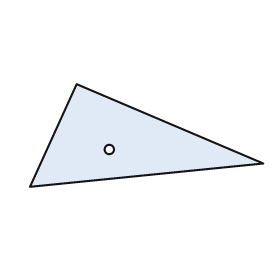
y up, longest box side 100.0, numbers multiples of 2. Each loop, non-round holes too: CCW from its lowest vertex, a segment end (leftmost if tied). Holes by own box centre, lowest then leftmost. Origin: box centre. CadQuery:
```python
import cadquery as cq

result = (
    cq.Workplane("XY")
    .moveTo(-50.0, -22.0)
    .lineTo(50.0, -12.0)
    .lineTo(-30.0, 22.0)
    .close()
    .moveTo(-16.0, -6.0)
    .circle(2.0)
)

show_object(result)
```